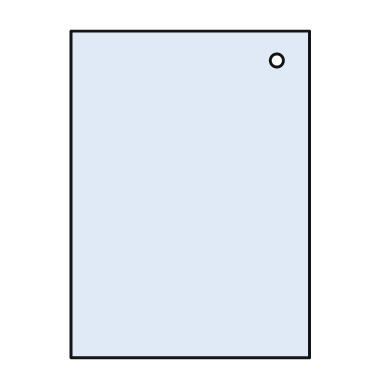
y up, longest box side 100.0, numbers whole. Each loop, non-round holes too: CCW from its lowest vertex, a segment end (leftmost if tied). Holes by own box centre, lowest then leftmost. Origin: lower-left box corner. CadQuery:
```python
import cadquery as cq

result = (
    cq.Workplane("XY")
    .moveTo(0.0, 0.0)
    .lineTo(73.0, 0.0)
    .lineTo(73.0, 100.0)
    .lineTo(0.0, 100.0)
    .close()
    .moveTo(63.0, 91.0)
    .circle(2.0)
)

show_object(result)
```